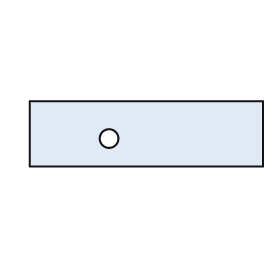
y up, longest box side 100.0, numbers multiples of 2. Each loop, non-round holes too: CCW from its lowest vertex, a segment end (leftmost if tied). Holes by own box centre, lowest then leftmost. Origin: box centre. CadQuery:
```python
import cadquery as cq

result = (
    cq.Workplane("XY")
    .moveTo(-50.0, -14.0)
    .lineTo(50.0, -14.0)
    .lineTo(50.0, 14.0)
    .lineTo(-50.0, 14.0)
    .close()
    .moveTo(-16.0, -2.0)
    .circle(4.0)
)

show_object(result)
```